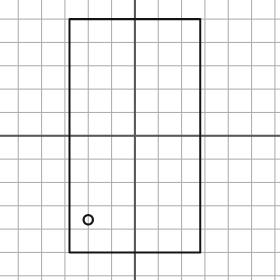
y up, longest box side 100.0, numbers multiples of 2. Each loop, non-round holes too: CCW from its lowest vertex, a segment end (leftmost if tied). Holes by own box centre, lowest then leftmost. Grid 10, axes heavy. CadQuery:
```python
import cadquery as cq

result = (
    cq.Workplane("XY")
    .moveTo(-28.0, -50.0)
    .lineTo(28.0, -50.0)
    .lineTo(28.0, 50.0)
    .lineTo(-28.0, 50.0)
    .close()
    .moveTo(-20.0, -36.0)
    .circle(2.0)
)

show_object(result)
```